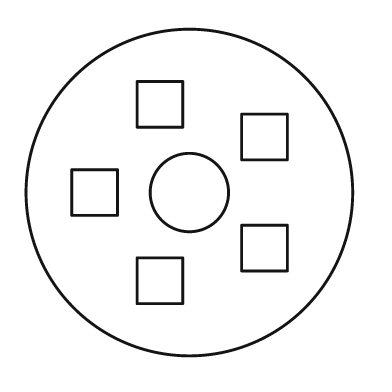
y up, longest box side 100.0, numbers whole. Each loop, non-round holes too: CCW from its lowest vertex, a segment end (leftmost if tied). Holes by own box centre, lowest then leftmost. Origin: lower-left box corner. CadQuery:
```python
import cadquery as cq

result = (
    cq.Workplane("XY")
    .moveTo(50.0, 50.0)
    .circle(50.0)
    .moveTo(34.0, 16.0)
    .lineTo(48.0, 16.0)
    .lineTo(48.0, 30.0)
    .lineTo(34.0, 30.0)
    .close()
    .moveTo(66.0, 26.0)
    .lineTo(80.0, 26.0)
    .lineTo(80.0, 40.0)
    .lineTo(66.0, 40.0)
    .close()
    .moveTo(14.0, 43.0)
    .lineTo(28.0, 43.0)
    .lineTo(28.0, 57.0)
    .lineTo(14.0, 57.0)
    .close()
    .moveTo(50.0, 50.0)
    .circle(12.0)
    .moveTo(66.0, 60.0)
    .lineTo(80.0, 60.0)
    .lineTo(80.0, 74.0)
    .lineTo(66.0, 74.0)
    .close()
    .moveTo(34.0, 70.0)
    .lineTo(48.0, 70.0)
    .lineTo(48.0, 84.0)
    .lineTo(34.0, 84.0)
    .close()
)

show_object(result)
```